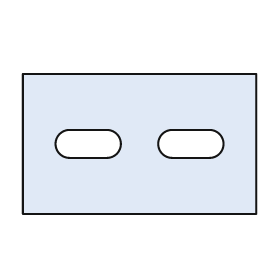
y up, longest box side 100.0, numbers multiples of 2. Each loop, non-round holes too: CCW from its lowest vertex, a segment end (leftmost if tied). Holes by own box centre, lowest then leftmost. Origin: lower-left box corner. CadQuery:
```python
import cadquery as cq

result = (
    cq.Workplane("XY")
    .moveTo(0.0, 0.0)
    .lineTo(100.0, 0.0)
    .lineTo(100.0, 60.0)
    .lineTo(0.0, 60.0)
    .close()
    .moveTo(20.0, 24.0)
    .lineTo(36.0, 24.0)
    .threePointArc((42.0, 30.0), (36.0, 36.0))
    .lineTo(20.0, 36.0)
    .threePointArc((14.0, 30.0), (20.0, 24.0))
    .close()
    .moveTo(64.0, 24.0)
    .lineTo(80.0, 24.0)
    .threePointArc((86.0, 30.0), (80.0, 36.0))
    .lineTo(64.0, 36.0)
    .threePointArc((58.0, 30.0), (64.0, 24.0))
    .close()
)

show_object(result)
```